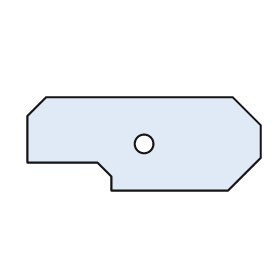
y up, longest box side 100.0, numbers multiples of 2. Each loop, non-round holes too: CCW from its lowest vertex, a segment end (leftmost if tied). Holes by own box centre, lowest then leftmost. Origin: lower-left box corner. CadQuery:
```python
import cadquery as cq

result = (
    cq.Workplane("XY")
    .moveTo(36.0, 0.0)
    .lineTo(86.0, 0.0)
    .lineTo(100.0, 14.0)
    .lineTo(100.0, 28.0)
    .lineTo(88.0, 40.0)
    .lineTo(8.0, 40.0)
    .lineTo(0.0, 32.0)
    .lineTo(0.0, 12.0)
    .lineTo(30.0, 12.0)
    .lineTo(36.0, 6.0)
    .close()
    .moveTo(50.0, 20.0)
    .circle(4.0)
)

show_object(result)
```